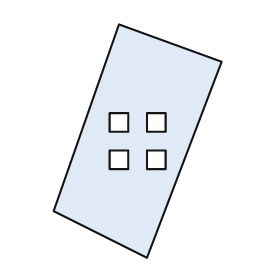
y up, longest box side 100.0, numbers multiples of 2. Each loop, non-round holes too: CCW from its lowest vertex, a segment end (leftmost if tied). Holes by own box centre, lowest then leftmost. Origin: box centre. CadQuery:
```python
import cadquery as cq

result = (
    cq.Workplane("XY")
    .moveTo(4.0, -50.0)
    .lineTo(36.0, 34.0)
    .lineTo(-8.0, 50.0)
    .lineTo(-36.0, -30.0)
    .close()
    .moveTo(-12.0, -12.0)
    .lineTo(-4.0, -12.0)
    .lineTo(-4.0, -4.0)
    .lineTo(-12.0, -4.0)
    .close()
    .moveTo(4.0, -12.0)
    .lineTo(12.0, -12.0)
    .lineTo(12.0, -4.0)
    .lineTo(4.0, -4.0)
    .close()
    .moveTo(-12.0, 4.0)
    .lineTo(-4.0, 4.0)
    .lineTo(-4.0, 12.0)
    .lineTo(-12.0, 12.0)
    .close()
    .moveTo(4.0, 4.0)
    .lineTo(12.0, 4.0)
    .lineTo(12.0, 12.0)
    .lineTo(4.0, 12.0)
    .close()
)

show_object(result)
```